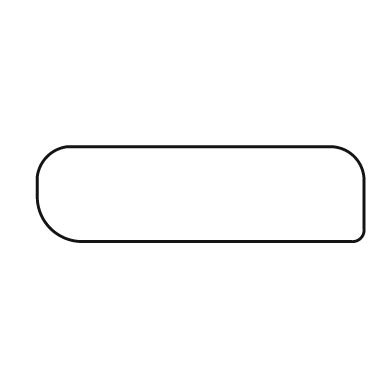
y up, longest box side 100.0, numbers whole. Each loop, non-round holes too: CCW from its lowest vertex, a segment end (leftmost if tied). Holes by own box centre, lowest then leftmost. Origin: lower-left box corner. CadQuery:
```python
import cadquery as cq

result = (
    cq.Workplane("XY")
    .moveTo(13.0, 0.0)
    .lineTo(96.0, 0.0)
    .threePointArc((99.0, 1.0), (100.0, 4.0))
    .lineTo(100.0, 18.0)
    .threePointArc((97.0, 26.0), (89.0, 29.0))
    .lineTo(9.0, 29.0)
    .threePointArc((3.0, 26.0), (0.0, 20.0))
    .lineTo(0.0, 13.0)
    .threePointArc((4.0, 4.0), (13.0, 0.0))
    .close()
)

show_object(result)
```